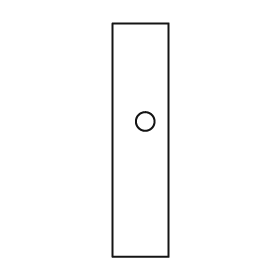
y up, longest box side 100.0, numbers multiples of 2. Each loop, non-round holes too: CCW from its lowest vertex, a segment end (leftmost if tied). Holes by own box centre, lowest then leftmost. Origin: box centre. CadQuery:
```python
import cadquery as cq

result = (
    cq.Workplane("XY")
    .moveTo(-12.0, -50.0)
    .lineTo(12.0, -50.0)
    .lineTo(12.0, 50.0)
    .lineTo(-12.0, 50.0)
    .close()
    .moveTo(2.0, 8.0)
    .circle(4.0)
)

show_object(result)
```